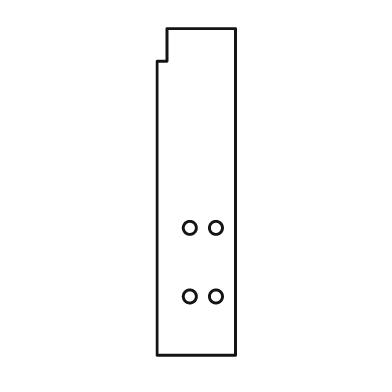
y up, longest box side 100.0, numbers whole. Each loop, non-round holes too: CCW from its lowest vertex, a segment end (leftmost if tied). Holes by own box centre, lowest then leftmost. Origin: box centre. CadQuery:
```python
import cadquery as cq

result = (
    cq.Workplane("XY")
    .moveTo(-12.0, -50.0)
    .lineTo(12.0, -50.0)
    .lineTo(12.0, 50.0)
    .lineTo(-9.0, 50.0)
    .lineTo(-9.0, 40.0)
    .lineTo(-12.0, 40.0)
    .close()
    .moveTo(-2.0, -32.0)
    .circle(2.0)
    .moveTo(6.0, -32.0)
    .circle(2.0)
    .moveTo(-2.0, -11.0)
    .circle(2.0)
    .moveTo(6.0, -11.0)
    .circle(2.0)
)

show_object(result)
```